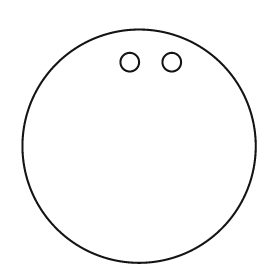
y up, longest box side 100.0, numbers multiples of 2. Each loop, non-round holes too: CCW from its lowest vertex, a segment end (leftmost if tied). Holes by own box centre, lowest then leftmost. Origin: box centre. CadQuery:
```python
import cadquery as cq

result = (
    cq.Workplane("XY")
    .moveTo(0.0, 0.0)
    .circle(50.0)
    .moveTo(-4.0, 36.0)
    .circle(4.0)
    .moveTo(14.0, 36.0)
    .circle(4.0)
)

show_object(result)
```